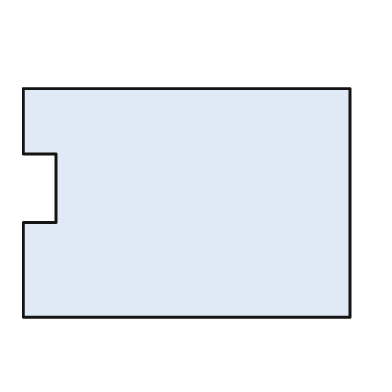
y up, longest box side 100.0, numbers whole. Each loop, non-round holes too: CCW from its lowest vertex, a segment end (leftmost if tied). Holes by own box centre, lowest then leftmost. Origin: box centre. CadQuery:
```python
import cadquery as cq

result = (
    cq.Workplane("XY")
    .moveTo(-50.0, -35.0)
    .lineTo(50.0, -35.0)
    .lineTo(50.0, 35.0)
    .lineTo(-50.0, 35.0)
    .lineTo(-50.0, 15.0)
    .lineTo(-40.0, 15.0)
    .lineTo(-40.0, -6.0)
    .lineTo(-50.0, -6.0)
    .close()
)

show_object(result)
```